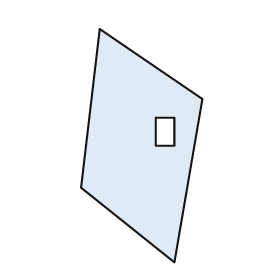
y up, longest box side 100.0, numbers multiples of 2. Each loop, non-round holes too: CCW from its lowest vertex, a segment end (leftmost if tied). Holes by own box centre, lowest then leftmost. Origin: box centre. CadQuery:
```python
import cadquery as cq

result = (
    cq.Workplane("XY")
    .moveTo(14.0, -50.0)
    .lineTo(26.0, 20.0)
    .lineTo(-18.0, 50.0)
    .lineTo(-26.0, -18.0)
    .close()
    .moveTo(6.0, 0.0)
    .lineTo(14.0, 0.0)
    .lineTo(14.0, 12.0)
    .lineTo(6.0, 12.0)
    .close()
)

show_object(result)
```